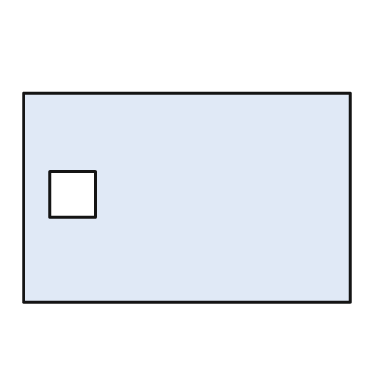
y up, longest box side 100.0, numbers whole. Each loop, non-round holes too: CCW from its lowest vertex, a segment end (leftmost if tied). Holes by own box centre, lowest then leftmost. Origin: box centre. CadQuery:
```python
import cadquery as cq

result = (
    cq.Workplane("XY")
    .moveTo(-50.0, -32.0)
    .lineTo(50.0, -32.0)
    .lineTo(50.0, 32.0)
    .lineTo(-50.0, 32.0)
    .close()
    .moveTo(-42.0, -6.0)
    .lineTo(-28.0, -6.0)
    .lineTo(-28.0, 8.0)
    .lineTo(-42.0, 8.0)
    .close()
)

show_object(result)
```